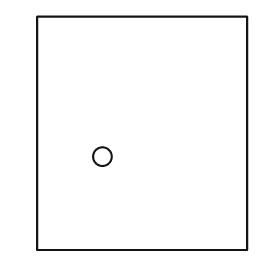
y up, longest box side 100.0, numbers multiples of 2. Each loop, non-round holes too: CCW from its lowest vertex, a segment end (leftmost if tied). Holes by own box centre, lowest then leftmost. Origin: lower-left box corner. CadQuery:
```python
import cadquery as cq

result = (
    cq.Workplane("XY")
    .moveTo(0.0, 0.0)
    .lineTo(90.0, 0.0)
    .lineTo(90.0, 100.0)
    .lineTo(0.0, 100.0)
    .close()
    .moveTo(28.0, 40.0)
    .circle(4.0)
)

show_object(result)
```